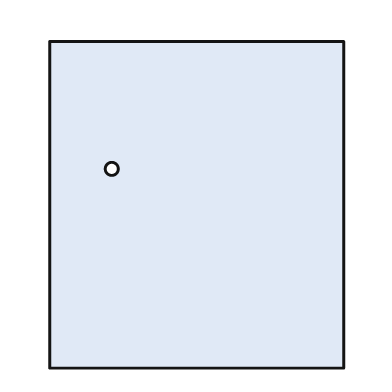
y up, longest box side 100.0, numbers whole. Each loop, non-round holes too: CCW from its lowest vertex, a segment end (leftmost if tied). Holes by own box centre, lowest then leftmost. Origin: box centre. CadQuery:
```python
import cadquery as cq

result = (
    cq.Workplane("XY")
    .moveTo(-45.0, -50.0)
    .lineTo(45.0, -50.0)
    .lineTo(45.0, 50.0)
    .lineTo(-45.0, 50.0)
    .close()
    .moveTo(-26.0, 11.0)
    .circle(2.0)
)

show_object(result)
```